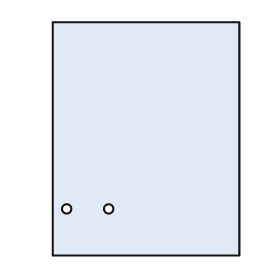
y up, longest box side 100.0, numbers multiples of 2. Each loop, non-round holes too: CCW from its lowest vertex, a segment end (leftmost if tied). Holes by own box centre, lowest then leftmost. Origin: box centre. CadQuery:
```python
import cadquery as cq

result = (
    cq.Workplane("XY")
    .moveTo(-40.0, -50.0)
    .lineTo(40.0, -50.0)
    .lineTo(40.0, 50.0)
    .lineTo(-40.0, 50.0)
    .close()
    .moveTo(-34.0, -30.0)
    .circle(2.0)
    .moveTo(-16.0, -30.0)
    .circle(2.0)
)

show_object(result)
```